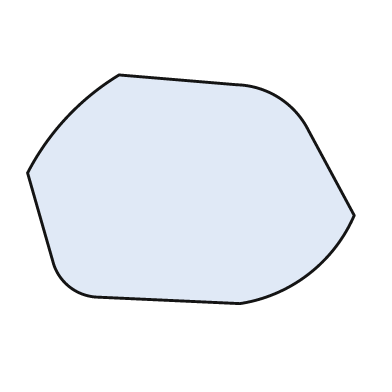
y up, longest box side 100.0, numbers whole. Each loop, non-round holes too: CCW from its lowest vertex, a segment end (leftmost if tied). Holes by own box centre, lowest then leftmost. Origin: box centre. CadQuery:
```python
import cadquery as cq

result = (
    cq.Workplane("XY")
    .moveTo(15.0, -35.0)
    .threePointArc((36.0, -26.0), (50.0, -8.0))
    .lineTo(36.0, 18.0)
    .threePointArc((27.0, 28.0), (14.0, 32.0))
    .lineTo(-22.0, 35.0)
    .threePointArc((-38.0, 22.0), (-50.0, 5.0))
    .lineTo(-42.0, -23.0)
    .threePointArc((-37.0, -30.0), (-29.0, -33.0))
    .close()
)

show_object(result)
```